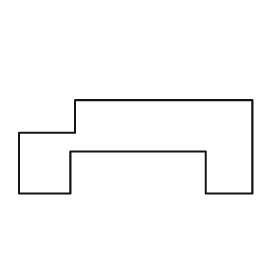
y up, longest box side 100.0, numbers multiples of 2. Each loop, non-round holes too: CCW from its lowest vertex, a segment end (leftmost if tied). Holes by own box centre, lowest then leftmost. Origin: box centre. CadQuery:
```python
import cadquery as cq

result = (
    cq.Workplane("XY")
    .moveTo(-50.0, -20.0)
    .lineTo(-28.0, -20.0)
    .lineTo(-28.0, -2.0)
    .lineTo(30.0, -2.0)
    .lineTo(30.0, -20.0)
    .lineTo(50.0, -20.0)
    .lineTo(50.0, 20.0)
    .lineTo(-26.0, 20.0)
    .lineTo(-26.0, 6.0)
    .lineTo(-50.0, 6.0)
    .close()
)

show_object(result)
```